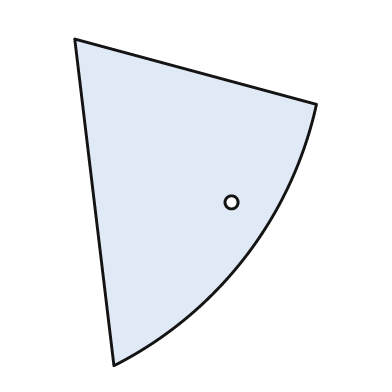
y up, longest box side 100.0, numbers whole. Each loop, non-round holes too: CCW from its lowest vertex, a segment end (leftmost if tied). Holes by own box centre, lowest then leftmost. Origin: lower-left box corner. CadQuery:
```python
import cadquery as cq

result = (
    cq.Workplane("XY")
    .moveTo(12.0, 0.0)
    .threePointArc((52.0, 33.0), (74.0, 80.0))
    .lineTo(0.0, 100.0)
    .close()
    .moveTo(48.0, 50.0)
    .circle(2.0)
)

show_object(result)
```